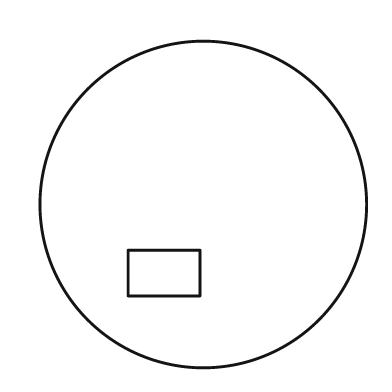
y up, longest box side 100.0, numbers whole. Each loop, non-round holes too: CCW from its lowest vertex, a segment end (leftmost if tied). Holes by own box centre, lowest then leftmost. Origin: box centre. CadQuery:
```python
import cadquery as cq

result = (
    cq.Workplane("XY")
    .moveTo(0.0, 0.0)
    .circle(50.0)
    .moveTo(-23.0, -28.0)
    .lineTo(-1.0, -28.0)
    .lineTo(-1.0, -14.0)
    .lineTo(-23.0, -14.0)
    .close()
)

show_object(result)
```